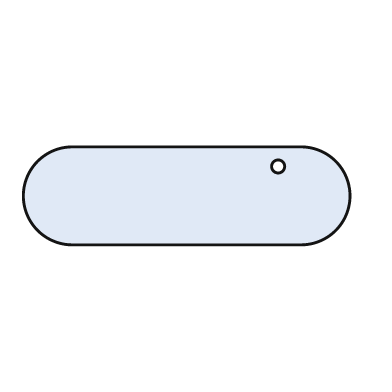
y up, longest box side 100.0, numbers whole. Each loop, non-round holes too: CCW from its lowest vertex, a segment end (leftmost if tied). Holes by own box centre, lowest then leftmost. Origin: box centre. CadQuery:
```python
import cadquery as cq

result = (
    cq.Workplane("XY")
    .moveTo(-35.0, -15.0)
    .lineTo(35.0, -15.0)
    .threePointArc((50.0, 0.0), (35.0, 15.0))
    .lineTo(-35.0, 15.0)
    .threePointArc((-50.0, 0.0), (-35.0, -15.0))
    .close()
    .moveTo(28.0, 9.0)
    .circle(2.0)
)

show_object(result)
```